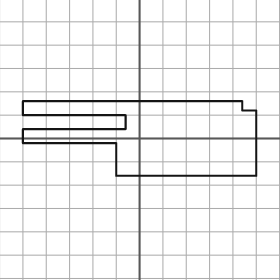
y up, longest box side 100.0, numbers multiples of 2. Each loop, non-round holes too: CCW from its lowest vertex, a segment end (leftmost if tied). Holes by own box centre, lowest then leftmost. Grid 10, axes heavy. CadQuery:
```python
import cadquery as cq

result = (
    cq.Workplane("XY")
    .moveTo(-10.0, -16.0)
    .lineTo(50.0, -16.0)
    .lineTo(50.0, 12.0)
    .lineTo(44.0, 12.0)
    .lineTo(44.0, 16.0)
    .lineTo(-50.0, 16.0)
    .lineTo(-50.0, 10.0)
    .lineTo(-6.0, 10.0)
    .lineTo(-6.0, 4.0)
    .lineTo(-50.0, 4.0)
    .lineTo(-50.0, -2.0)
    .lineTo(-10.0, -2.0)
    .close()
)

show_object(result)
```